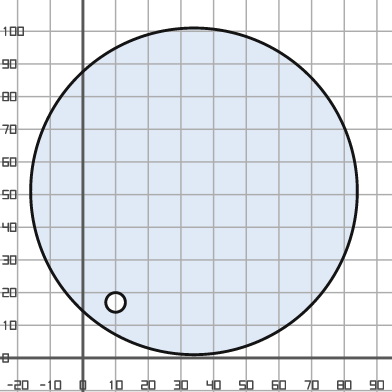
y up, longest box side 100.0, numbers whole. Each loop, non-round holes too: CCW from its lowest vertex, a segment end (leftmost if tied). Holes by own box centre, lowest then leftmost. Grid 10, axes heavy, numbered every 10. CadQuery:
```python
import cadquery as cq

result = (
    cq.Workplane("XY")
    .moveTo(34.0, 51.0)
    .circle(50.0)
    .moveTo(10.0, 17.0)
    .circle(3.0)
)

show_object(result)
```